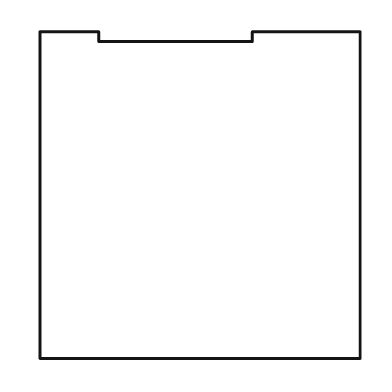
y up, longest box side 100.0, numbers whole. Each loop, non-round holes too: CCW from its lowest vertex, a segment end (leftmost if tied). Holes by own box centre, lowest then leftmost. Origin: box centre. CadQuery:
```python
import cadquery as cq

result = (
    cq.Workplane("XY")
    .moveTo(-49.0, -50.0)
    .lineTo(49.0, -50.0)
    .lineTo(49.0, 50.0)
    .lineTo(16.0, 50.0)
    .lineTo(16.0, 47.0)
    .lineTo(-31.0, 47.0)
    .lineTo(-31.0, 50.0)
    .lineTo(-49.0, 50.0)
    .close()
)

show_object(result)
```